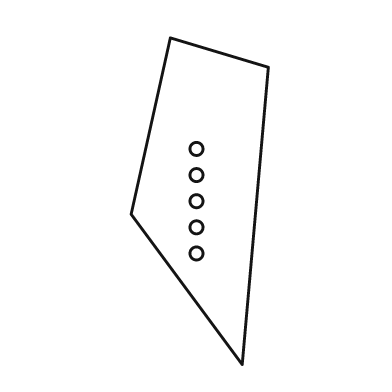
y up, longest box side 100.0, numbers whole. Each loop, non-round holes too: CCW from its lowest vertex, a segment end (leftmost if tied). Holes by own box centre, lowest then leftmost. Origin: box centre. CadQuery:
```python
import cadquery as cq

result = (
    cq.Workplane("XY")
    .moveTo(13.0, -50.0)
    .lineTo(21.0, 41.0)
    .lineTo(-9.0, 50.0)
    .lineTo(-21.0, -4.0)
    .close()
    .moveTo(-1.0, -16.0)
    .circle(2.0)
    .moveTo(-1.0, -8.0)
    .circle(2.0)
    .moveTo(-1.0, 0.0)
    .circle(2.0)
    .moveTo(-1.0, 8.0)
    .circle(2.0)
    .moveTo(-1.0, 16.0)
    .circle(2.0)
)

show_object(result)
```